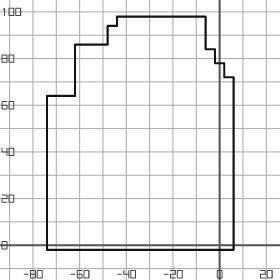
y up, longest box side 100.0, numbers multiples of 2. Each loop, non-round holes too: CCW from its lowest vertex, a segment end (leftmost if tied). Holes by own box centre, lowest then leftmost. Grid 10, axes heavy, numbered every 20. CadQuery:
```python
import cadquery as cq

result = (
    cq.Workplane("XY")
    .moveTo(-74.0, -2.0)
    .lineTo(6.0, -2.0)
    .lineTo(6.0, 72.0)
    .lineTo(2.0, 72.0)
    .lineTo(2.0, 78.0)
    .lineTo(-2.0, 78.0)
    .lineTo(-2.0, 84.0)
    .lineTo(-6.0, 84.0)
    .lineTo(-6.0, 98.0)
    .lineTo(-44.0, 98.0)
    .lineTo(-44.0, 94.0)
    .lineTo(-48.0, 94.0)
    .lineTo(-48.0, 86.0)
    .lineTo(-62.0, 86.0)
    .lineTo(-62.0, 64.0)
    .lineTo(-74.0, 64.0)
    .close()
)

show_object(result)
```